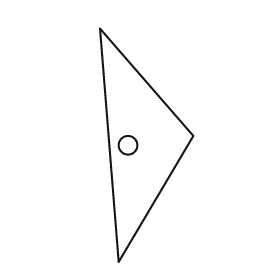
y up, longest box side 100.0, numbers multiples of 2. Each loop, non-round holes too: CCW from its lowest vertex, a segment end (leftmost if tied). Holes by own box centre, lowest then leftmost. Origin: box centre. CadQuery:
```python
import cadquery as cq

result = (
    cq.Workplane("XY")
    .moveTo(-12.0, -50.0)
    .lineTo(20.0, 4.0)
    .lineTo(-20.0, 50.0)
    .close()
    .moveTo(-8.0, 0.0)
    .circle(4.0)
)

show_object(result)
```